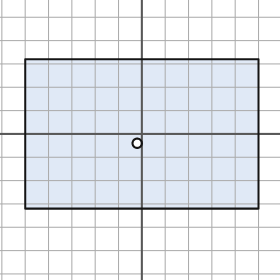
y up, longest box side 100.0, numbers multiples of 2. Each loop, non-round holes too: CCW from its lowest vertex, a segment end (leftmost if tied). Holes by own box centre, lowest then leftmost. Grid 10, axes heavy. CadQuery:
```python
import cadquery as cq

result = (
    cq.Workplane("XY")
    .moveTo(-50.0, -32.0)
    .lineTo(50.0, -32.0)
    .lineTo(50.0, 32.0)
    .lineTo(-50.0, 32.0)
    .close()
    .moveTo(-2.0, -4.0)
    .circle(2.0)
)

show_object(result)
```